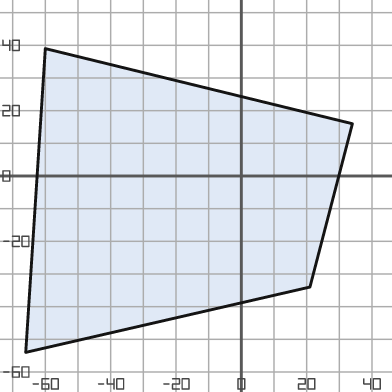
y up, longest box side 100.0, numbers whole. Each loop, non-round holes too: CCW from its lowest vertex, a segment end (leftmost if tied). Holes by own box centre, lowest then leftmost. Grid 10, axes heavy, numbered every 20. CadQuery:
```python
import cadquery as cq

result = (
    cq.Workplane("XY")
    .moveTo(-66.0, -54.0)
    .lineTo(21.0, -34.0)
    .lineTo(34.0, 16.0)
    .lineTo(-60.0, 39.0)
    .close()
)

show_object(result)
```